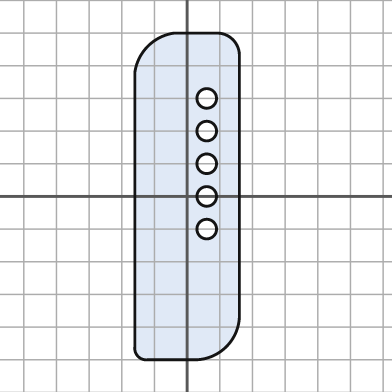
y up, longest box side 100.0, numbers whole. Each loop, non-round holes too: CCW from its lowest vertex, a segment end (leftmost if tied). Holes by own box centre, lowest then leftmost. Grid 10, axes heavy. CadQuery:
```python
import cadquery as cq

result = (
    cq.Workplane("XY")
    .moveTo(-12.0, -50.0)
    .lineTo(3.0, -50.0)
    .threePointArc((12.0, -46.0), (16.0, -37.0))
    .lineTo(16.0, 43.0)
    .threePointArc((14.0, 48.0), (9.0, 50.0))
    .lineTo(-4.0, 50.0)
    .threePointArc((-12.0, 46.0), (-16.0, 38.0))
    .lineTo(-16.0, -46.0)
    .threePointArc((-15.0, -49.0), (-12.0, -50.0))
    .close()
    .moveTo(6.0, -10.0)
    .circle(3.0)
    .moveTo(6.0, 0.0)
    .circle(3.0)
    .moveTo(6.0, 10.0)
    .circle(3.0)
    .moveTo(6.0, 20.0)
    .circle(3.0)
    .moveTo(6.0, 30.0)
    .circle(3.0)
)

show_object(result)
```